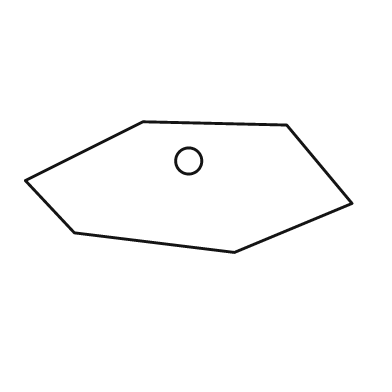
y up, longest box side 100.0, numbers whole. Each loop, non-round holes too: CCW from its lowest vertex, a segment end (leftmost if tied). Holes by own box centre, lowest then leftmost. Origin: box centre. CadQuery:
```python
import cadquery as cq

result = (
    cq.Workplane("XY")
    .moveTo(14.0, -20.0)
    .lineTo(50.0, -5.0)
    .lineTo(30.0, 19.0)
    .lineTo(-14.0, 20.0)
    .lineTo(-50.0, 2.0)
    .lineTo(-35.0, -14.0)
    .close()
    .moveTo(0.0, 8.0)
    .circle(4.0)
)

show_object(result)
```